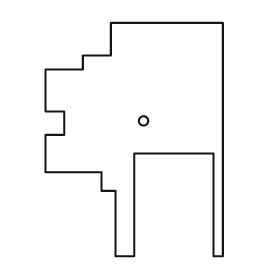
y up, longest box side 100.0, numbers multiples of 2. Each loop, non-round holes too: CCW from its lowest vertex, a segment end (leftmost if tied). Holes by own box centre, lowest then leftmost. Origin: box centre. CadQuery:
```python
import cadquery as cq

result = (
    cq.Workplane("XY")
    .moveTo(-8.0, -50.0)
    .lineTo(0.0, -50.0)
    .lineTo(0.0, -6.0)
    .lineTo(34.0, -6.0)
    .lineTo(34.0, -50.0)
    .lineTo(38.0, -50.0)
    .lineTo(38.0, 50.0)
    .lineTo(-10.0, 50.0)
    .lineTo(-10.0, 36.0)
    .lineTo(-22.0, 36.0)
    .lineTo(-22.0, 30.0)
    .lineTo(-38.0, 30.0)
    .lineTo(-38.0, 12.0)
    .lineTo(-30.0, 12.0)
    .lineTo(-30.0, 2.0)
    .lineTo(-38.0, 2.0)
    .lineTo(-38.0, -14.0)
    .lineTo(-14.0, -14.0)
    .lineTo(-14.0, -22.0)
    .lineTo(-8.0, -22.0)
    .close()
    .moveTo(4.0, 8.0)
    .circle(2.0)
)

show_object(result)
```